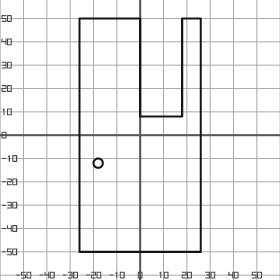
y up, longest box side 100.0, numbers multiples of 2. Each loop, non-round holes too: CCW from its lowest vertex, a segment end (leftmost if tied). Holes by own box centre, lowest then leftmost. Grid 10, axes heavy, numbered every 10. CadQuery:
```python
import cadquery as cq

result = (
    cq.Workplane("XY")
    .moveTo(-26.0, -50.0)
    .lineTo(26.0, -50.0)
    .lineTo(26.0, 50.0)
    .lineTo(18.0, 50.0)
    .lineTo(18.0, 8.0)
    .lineTo(0.0, 8.0)
    .lineTo(0.0, 50.0)
    .lineTo(-26.0, 50.0)
    .close()
    .moveTo(-18.0, -12.0)
    .circle(2.0)
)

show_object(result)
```